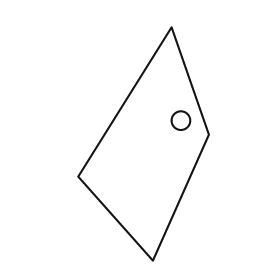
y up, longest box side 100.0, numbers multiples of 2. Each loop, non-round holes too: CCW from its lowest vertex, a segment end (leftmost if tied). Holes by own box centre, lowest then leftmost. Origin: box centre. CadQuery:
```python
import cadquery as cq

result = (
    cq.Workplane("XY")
    .moveTo(4.0, -50.0)
    .lineTo(28.0, 4.0)
    .lineTo(12.0, 50.0)
    .lineTo(-28.0, -14.0)
    .close()
    .moveTo(16.0, 10.0)
    .circle(4.0)
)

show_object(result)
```